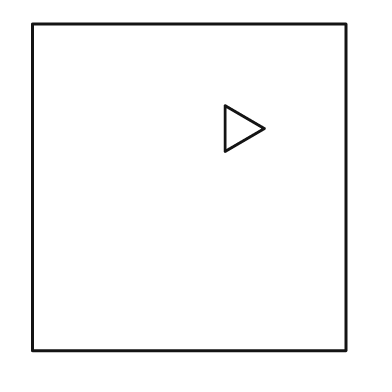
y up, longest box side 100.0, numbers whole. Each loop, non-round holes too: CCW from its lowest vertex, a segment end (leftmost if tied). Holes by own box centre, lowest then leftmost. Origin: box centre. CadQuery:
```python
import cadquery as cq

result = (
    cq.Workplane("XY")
    .moveTo(-48.0, -50.0)
    .lineTo(48.0, -50.0)
    .lineTo(48.0, 50.0)
    .lineTo(-48.0, 50.0)
    .close()
    .moveTo(11.0, 11.0)
    .lineTo(23.0, 18.0)
    .lineTo(11.0, 25.0)
    .close()
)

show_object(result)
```